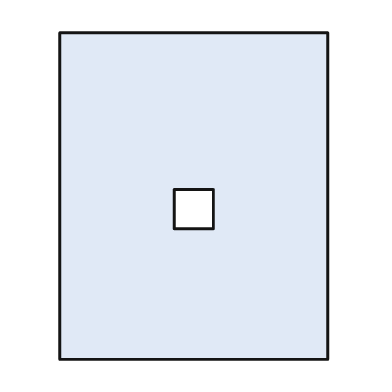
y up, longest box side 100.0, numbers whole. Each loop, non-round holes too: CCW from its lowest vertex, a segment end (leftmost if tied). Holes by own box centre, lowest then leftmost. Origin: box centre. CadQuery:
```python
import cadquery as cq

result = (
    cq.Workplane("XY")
    .moveTo(-41.0, -50.0)
    .lineTo(41.0, -50.0)
    .lineTo(41.0, 50.0)
    .lineTo(-41.0, 50.0)
    .close()
    .moveTo(-6.0, -10.0)
    .lineTo(6.0, -10.0)
    .lineTo(6.0, 2.0)
    .lineTo(-6.0, 2.0)
    .close()
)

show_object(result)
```